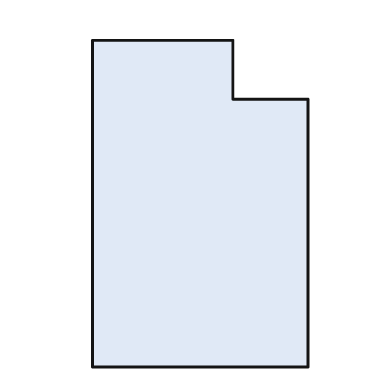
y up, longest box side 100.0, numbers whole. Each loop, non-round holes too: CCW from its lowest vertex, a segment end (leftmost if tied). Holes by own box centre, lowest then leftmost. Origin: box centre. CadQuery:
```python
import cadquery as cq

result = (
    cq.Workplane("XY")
    .moveTo(-33.0, -50.0)
    .lineTo(33.0, -50.0)
    .lineTo(33.0, 32.0)
    .lineTo(10.0, 32.0)
    .lineTo(10.0, 50.0)
    .lineTo(-33.0, 50.0)
    .close()
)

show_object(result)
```